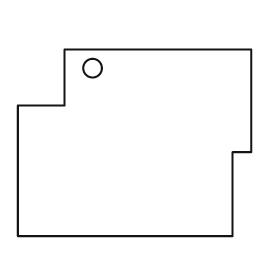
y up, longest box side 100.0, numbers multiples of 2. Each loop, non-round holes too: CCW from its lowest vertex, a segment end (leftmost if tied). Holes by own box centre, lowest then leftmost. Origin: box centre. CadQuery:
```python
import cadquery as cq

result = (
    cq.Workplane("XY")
    .moveTo(-50.0, -40.0)
    .lineTo(42.0, -40.0)
    .lineTo(42.0, -4.0)
    .lineTo(50.0, -4.0)
    .lineTo(50.0, 40.0)
    .lineTo(-30.0, 40.0)
    .lineTo(-30.0, 16.0)
    .lineTo(-50.0, 16.0)
    .close()
    .moveTo(-18.0, 32.0)
    .circle(4.0)
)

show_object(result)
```